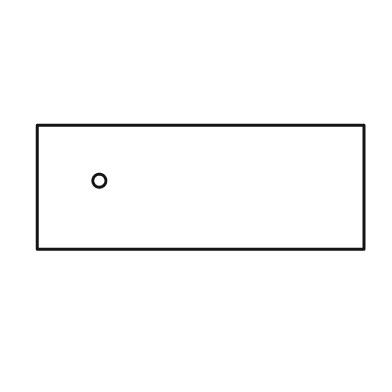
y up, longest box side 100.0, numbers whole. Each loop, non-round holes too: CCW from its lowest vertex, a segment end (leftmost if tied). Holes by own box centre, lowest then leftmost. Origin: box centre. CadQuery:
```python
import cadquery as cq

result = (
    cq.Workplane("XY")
    .moveTo(-50.0, -19.0)
    .lineTo(50.0, -19.0)
    .lineTo(50.0, 19.0)
    .lineTo(-50.0, 19.0)
    .close()
    .moveTo(-31.0, 2.0)
    .circle(2.0)
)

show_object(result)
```